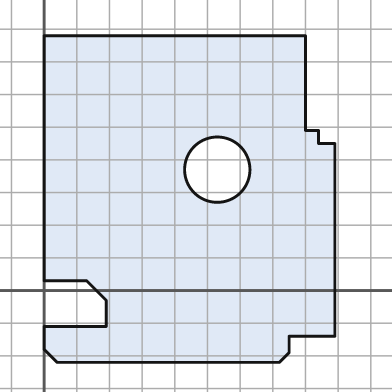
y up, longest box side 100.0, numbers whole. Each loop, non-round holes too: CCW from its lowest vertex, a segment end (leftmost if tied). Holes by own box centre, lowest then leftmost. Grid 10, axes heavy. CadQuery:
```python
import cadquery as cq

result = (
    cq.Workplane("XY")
    .moveTo(4.0, -22.0)
    .lineTo(72.0, -22.0)
    .lineTo(75.0, -19.0)
    .lineTo(75.0, -14.0)
    .lineTo(89.0, -14.0)
    .lineTo(89.0, 45.0)
    .lineTo(84.0, 45.0)
    .lineTo(84.0, 49.0)
    .lineTo(80.0, 49.0)
    .lineTo(80.0, 78.0)
    .lineTo(0.0, 78.0)
    .lineTo(0.0, 3.0)
    .lineTo(13.0, 3.0)
    .lineTo(19.0, -3.0)
    .lineTo(19.0, -11.0)
    .lineTo(0.0, -11.0)
    .lineTo(0.0, -18.0)
    .close()
    .moveTo(53.0, 37.0)
    .circle(10.0)
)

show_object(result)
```